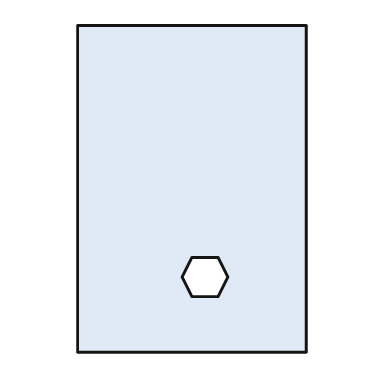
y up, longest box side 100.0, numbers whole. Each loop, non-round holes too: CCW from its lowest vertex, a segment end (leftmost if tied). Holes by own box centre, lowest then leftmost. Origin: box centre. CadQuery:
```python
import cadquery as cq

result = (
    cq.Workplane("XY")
    .moveTo(-35.0, -50.0)
    .lineTo(35.0, -50.0)
    .lineTo(35.0, 50.0)
    .lineTo(-35.0, 50.0)
    .close()
    .moveTo(0.0, -33.0)
    .lineTo(8.0, -33.0)
    .lineTo(11.0, -27.0)
    .lineTo(8.0, -21.0)
    .lineTo(0.0, -21.0)
    .lineTo(-3.0, -27.0)
    .close()
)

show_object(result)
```